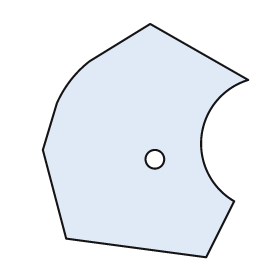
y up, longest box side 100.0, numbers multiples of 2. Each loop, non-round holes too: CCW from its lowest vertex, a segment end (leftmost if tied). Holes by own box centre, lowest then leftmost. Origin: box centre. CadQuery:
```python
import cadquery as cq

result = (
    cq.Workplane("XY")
    .moveTo(26.0, -50.0)
    .lineTo(38.0, -26.0)
    .threePointArc((24.0, 2.0), (44.0, 26.0))
    .lineTo(2.0, 50.0)
    .lineTo(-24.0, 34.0)
    .threePointArc((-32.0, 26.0), (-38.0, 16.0))
    .lineTo(-44.0, -4.0)
    .lineTo(-34.0, -42.0)
    .close()
    .moveTo(4.0, -8.0)
    .circle(4.0)
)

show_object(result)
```